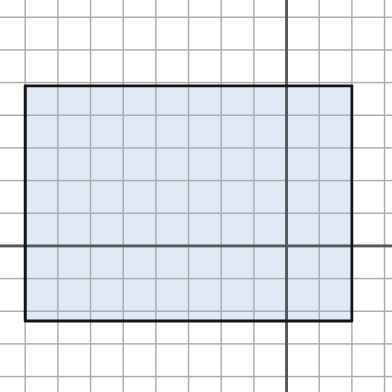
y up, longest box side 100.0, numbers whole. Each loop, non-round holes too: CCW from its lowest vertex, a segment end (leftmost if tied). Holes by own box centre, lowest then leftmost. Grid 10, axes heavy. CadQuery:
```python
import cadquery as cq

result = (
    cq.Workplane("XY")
    .moveTo(-80.0, -23.0)
    .lineTo(20.0, -23.0)
    .lineTo(20.0, 49.0)
    .lineTo(-80.0, 49.0)
    .close()
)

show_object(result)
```